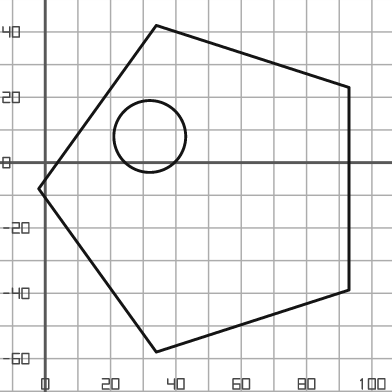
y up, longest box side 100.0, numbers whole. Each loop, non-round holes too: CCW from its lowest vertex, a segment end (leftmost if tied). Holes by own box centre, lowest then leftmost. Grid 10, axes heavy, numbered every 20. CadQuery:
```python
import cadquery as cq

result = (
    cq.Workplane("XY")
    .moveTo(34.0, -58.0)
    .lineTo(93.0, -39.0)
    .lineTo(93.0, 23.0)
    .lineTo(34.0, 42.0)
    .lineTo(-2.0, -8.0)
    .close()
    .moveTo(32.0, 8.0)
    .circle(11.0)
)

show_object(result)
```